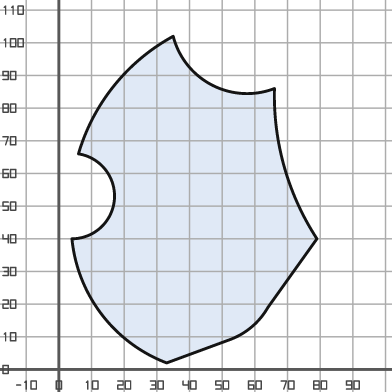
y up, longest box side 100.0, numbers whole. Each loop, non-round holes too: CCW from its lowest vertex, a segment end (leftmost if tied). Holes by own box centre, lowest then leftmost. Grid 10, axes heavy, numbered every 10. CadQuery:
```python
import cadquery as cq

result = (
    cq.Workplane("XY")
    .moveTo(33.0, 2.0)
    .lineTo(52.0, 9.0)
    .threePointArc((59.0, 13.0), (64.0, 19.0))
    .lineTo(79.0, 40.0)
    .threePointArc((69.0, 62.0), (66.0, 86.0))
    .threePointArc((47.0, 87.0), (35.0, 102.0))
    .threePointArc((17.0, 87.0), (6.0, 66.0))
    .threePointArc((17.0, 52.0), (4.0, 40.0))
    .threePointArc((13.0, 17.0), (33.0, 2.0))
    .close()
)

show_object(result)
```